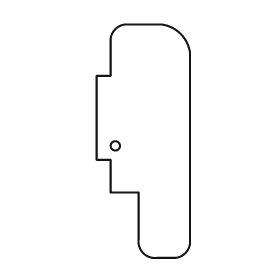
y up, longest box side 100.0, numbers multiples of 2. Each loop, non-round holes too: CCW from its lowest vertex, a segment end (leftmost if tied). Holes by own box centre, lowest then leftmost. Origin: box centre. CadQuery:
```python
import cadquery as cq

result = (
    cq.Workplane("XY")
    .moveTo(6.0, -50.0)
    .lineTo(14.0, -50.0)
    .threePointArc((18.0, -48.0), (20.0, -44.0))
    .lineTo(20.0, 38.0)
    .threePointArc((16.0, 46.0), (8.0, 50.0))
    .lineTo(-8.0, 50.0)
    .threePointArc((-12.0, 48.0), (-14.0, 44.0))
    .lineTo(-14.0, 28.0)
    .lineTo(-20.0, 28.0)
    .lineTo(-20.0, -8.0)
    .lineTo(-14.0, -8.0)
    .lineTo(-14.0, -22.0)
    .lineTo(-2.0, -22.0)
    .lineTo(-2.0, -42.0)
    .threePointArc((0.0, -48.0), (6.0, -50.0))
    .close()
    .moveTo(-12.0, -2.0)
    .circle(2.0)
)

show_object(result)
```